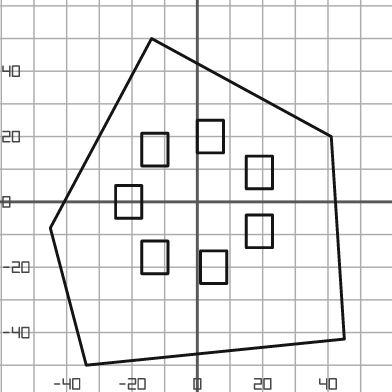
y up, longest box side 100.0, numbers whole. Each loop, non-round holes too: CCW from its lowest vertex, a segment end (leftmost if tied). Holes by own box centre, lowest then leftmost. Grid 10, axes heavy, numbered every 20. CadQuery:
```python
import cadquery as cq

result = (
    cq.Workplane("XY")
    .moveTo(-34.0, -50.0)
    .lineTo(45.0, -42.0)
    .lineTo(41.0, 20.0)
    .lineTo(-14.0, 50.0)
    .lineTo(-45.0, -8.0)
    .close()
    .moveTo(1.0, -25.0)
    .lineTo(9.0, -25.0)
    .lineTo(9.0, -15.0)
    .lineTo(1.0, -15.0)
    .close()
    .moveTo(-17.0, -22.0)
    .lineTo(-9.0, -22.0)
    .lineTo(-9.0, -12.0)
    .lineTo(-17.0, -12.0)
    .close()
    .moveTo(15.0, -14.0)
    .lineTo(23.0, -14.0)
    .lineTo(23.0, -4.0)
    .lineTo(15.0, -4.0)
    .close()
    .moveTo(-25.0, -5.0)
    .lineTo(-17.0, -5.0)
    .lineTo(-17.0, 5.0)
    .lineTo(-25.0, 5.0)
    .close()
    .moveTo(15.0, 4.0)
    .lineTo(23.0, 4.0)
    .lineTo(23.0, 14.0)
    .lineTo(15.0, 14.0)
    .close()
    .moveTo(-17.0, 11.0)
    .lineTo(-9.0, 11.0)
    .lineTo(-9.0, 21.0)
    .lineTo(-17.0, 21.0)
    .close()
    .moveTo(0.0, 15.0)
    .lineTo(8.0, 15.0)
    .lineTo(8.0, 25.0)
    .lineTo(0.0, 25.0)
    .close()
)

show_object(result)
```